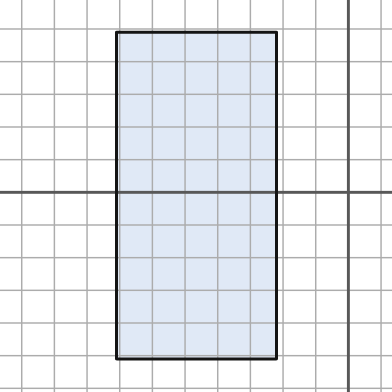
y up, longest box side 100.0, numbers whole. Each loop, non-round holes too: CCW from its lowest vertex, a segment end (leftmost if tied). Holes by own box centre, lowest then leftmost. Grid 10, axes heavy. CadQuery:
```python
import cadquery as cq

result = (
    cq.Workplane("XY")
    .moveTo(-71.0, -51.0)
    .lineTo(-22.0, -51.0)
    .lineTo(-22.0, 49.0)
    .lineTo(-71.0, 49.0)
    .close()
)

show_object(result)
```